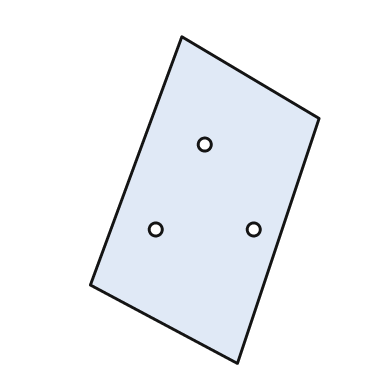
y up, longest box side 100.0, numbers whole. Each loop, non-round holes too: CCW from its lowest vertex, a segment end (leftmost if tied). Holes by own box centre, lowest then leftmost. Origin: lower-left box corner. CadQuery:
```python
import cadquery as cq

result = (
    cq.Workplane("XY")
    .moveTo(45.0, 0.0)
    .lineTo(70.0, 75.0)
    .lineTo(28.0, 100.0)
    .lineTo(0.0, 24.0)
    .close()
    .moveTo(20.0, 41.0)
    .circle(2.0)
    .moveTo(50.0, 41.0)
    .circle(2.0)
    .moveTo(35.0, 67.0)
    .circle(2.0)
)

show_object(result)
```